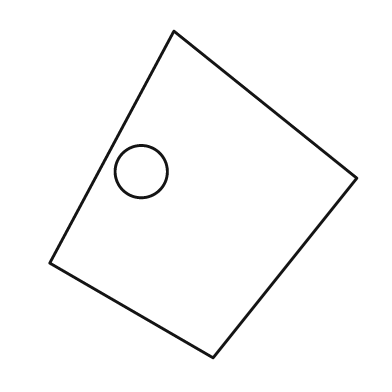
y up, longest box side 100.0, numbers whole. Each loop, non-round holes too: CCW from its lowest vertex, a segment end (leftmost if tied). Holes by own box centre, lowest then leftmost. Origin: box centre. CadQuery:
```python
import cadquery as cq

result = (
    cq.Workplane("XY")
    .moveTo(3.0, -50.0)
    .lineTo(47.0, 5.0)
    .lineTo(-9.0, 50.0)
    .lineTo(-47.0, -21.0)
    .close()
    .moveTo(-19.0, 7.0)
    .circle(8.0)
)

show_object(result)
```